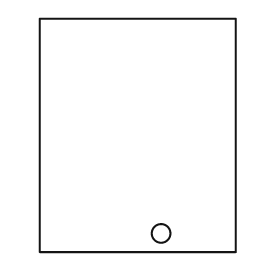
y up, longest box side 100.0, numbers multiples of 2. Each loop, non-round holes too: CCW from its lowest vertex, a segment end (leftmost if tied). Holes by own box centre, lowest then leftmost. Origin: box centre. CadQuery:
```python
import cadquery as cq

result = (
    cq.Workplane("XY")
    .moveTo(-42.0, -50.0)
    .lineTo(42.0, -50.0)
    .lineTo(42.0, 50.0)
    .lineTo(-42.0, 50.0)
    .close()
    .moveTo(10.0, -42.0)
    .circle(4.0)
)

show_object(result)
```